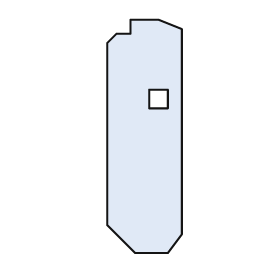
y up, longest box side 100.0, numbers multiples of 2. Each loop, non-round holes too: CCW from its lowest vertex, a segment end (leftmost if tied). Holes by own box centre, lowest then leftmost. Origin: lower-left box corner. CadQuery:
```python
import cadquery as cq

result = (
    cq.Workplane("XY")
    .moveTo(12.0, 0.0)
    .lineTo(26.0, 0.0)
    .lineTo(32.0, 8.0)
    .lineTo(32.0, 96.0)
    .lineTo(22.0, 100.0)
    .lineTo(10.0, 100.0)
    .lineTo(10.0, 94.0)
    .lineTo(4.0, 94.0)
    .lineTo(0.0, 90.0)
    .lineTo(0.0, 12.0)
    .close()
    .moveTo(18.0, 62.0)
    .lineTo(26.0, 62.0)
    .lineTo(26.0, 70.0)
    .lineTo(18.0, 70.0)
    .close()
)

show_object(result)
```